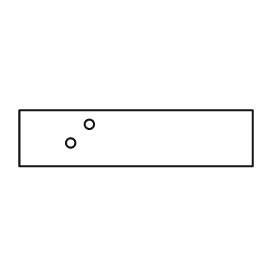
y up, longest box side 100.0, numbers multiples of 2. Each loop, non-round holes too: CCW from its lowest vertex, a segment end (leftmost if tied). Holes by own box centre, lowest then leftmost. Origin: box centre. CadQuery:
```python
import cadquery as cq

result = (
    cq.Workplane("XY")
    .moveTo(-50.0, -12.0)
    .lineTo(50.0, -12.0)
    .lineTo(50.0, 12.0)
    .lineTo(-50.0, 12.0)
    .close()
    .moveTo(-28.0, -2.0)
    .circle(2.0)
    .moveTo(-20.0, 6.0)
    .circle(2.0)
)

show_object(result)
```